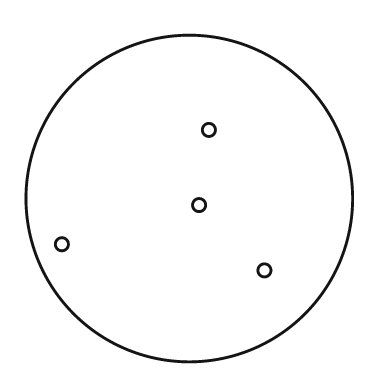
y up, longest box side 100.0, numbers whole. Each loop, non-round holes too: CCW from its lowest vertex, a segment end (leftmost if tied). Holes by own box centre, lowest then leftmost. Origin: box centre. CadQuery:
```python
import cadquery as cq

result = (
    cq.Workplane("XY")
    .moveTo(0.0, 0.0)
    .circle(50.0)
    .moveTo(23.0, -22.0)
    .circle(2.0)
    .moveTo(-39.0, -14.0)
    .circle(2.0)
    .moveTo(3.0, -2.0)
    .circle(2.0)
    .moveTo(6.0, 21.0)
    .circle(2.0)
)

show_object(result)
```